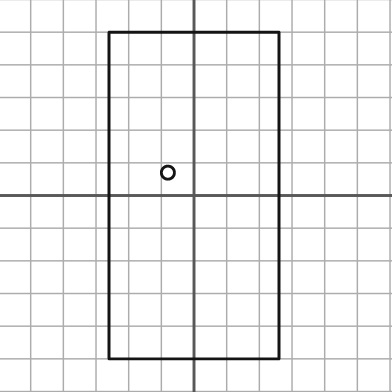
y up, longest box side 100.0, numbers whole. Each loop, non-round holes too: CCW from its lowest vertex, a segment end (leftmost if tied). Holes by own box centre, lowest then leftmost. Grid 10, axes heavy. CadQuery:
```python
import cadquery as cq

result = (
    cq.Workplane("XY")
    .moveTo(-26.0, -50.0)
    .lineTo(26.0, -50.0)
    .lineTo(26.0, 50.0)
    .lineTo(-26.0, 50.0)
    .close()
    .moveTo(-8.0, 7.0)
    .circle(2.0)
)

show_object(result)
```